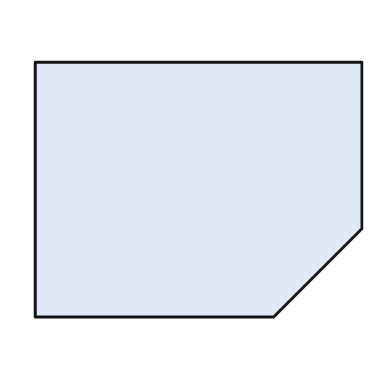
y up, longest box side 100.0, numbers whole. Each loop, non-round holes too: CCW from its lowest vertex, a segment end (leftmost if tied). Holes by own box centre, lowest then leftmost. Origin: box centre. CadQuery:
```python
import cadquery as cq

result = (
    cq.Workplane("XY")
    .moveTo(-50.0, -39.0)
    .lineTo(23.0, -39.0)
    .lineTo(50.0, -12.0)
    .lineTo(50.0, 39.0)
    .lineTo(-50.0, 39.0)
    .close()
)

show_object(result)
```